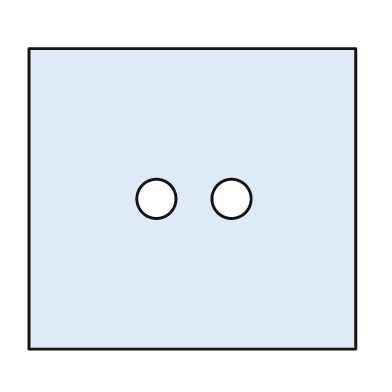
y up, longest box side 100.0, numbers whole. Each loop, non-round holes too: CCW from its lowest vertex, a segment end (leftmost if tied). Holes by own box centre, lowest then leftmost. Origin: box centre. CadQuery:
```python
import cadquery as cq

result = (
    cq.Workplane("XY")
    .moveTo(-50.0, -46.0)
    .lineTo(50.0, -46.0)
    .lineTo(50.0, 46.0)
    .lineTo(-50.0, 46.0)
    .close()
    .moveTo(-11.0, 0.0)
    .circle(6.0)
    .moveTo(12.0, 0.0)
    .circle(6.0)
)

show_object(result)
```